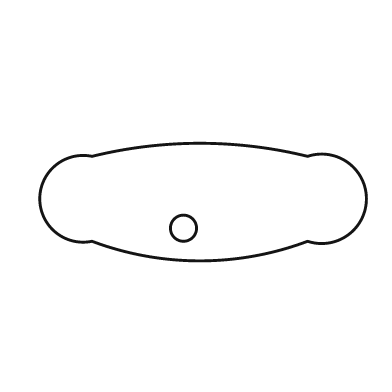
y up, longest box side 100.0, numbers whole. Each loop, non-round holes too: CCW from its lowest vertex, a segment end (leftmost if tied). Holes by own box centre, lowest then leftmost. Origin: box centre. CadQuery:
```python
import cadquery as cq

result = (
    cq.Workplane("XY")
    .moveTo(-34.0, -12.0)
    .threePointArc((-1.0, -18.0), (32.0, -12.0))
    .threePointArc((50.0, 1.0), (32.0, 14.0))
    .threePointArc((-1.0, 18.0), (-34.0, 14.0))
    .threePointArc((-50.0, 1.0), (-34.0, -12.0))
    .close()
    .moveTo(-6.0, -8.0)
    .circle(4.0)
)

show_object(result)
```